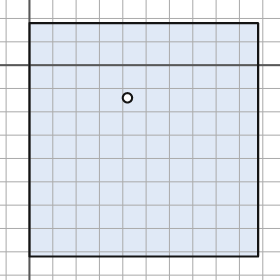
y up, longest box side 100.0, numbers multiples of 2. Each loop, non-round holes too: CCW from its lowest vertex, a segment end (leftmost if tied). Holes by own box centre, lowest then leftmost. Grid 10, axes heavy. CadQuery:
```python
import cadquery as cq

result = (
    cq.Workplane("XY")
    .moveTo(0.0, -82.0)
    .lineTo(98.0, -82.0)
    .lineTo(98.0, 18.0)
    .lineTo(0.0, 18.0)
    .close()
    .moveTo(42.0, -14.0)
    .circle(2.0)
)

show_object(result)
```